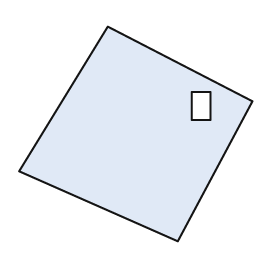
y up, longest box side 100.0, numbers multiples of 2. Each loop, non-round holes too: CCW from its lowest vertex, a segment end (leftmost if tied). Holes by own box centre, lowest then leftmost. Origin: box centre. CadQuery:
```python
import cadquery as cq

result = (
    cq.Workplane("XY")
    .moveTo(18.0, -46.0)
    .lineTo(50.0, 14.0)
    .lineTo(-12.0, 46.0)
    .lineTo(-50.0, -16.0)
    .close()
    .moveTo(24.0, 6.0)
    .lineTo(32.0, 6.0)
    .lineTo(32.0, 18.0)
    .lineTo(24.0, 18.0)
    .close()
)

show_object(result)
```